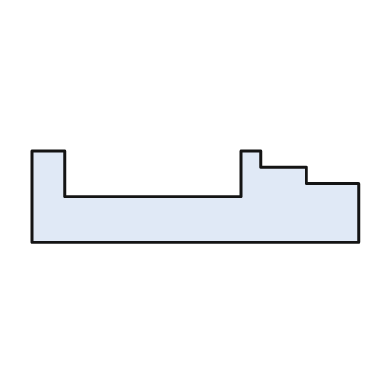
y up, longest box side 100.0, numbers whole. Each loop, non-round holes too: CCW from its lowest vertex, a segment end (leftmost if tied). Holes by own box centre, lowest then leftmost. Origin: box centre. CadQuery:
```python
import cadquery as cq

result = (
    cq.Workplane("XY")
    .moveTo(-50.0, -14.0)
    .lineTo(50.0, -14.0)
    .lineTo(50.0, 4.0)
    .lineTo(34.0, 4.0)
    .lineTo(34.0, 9.0)
    .lineTo(20.0, 9.0)
    .lineTo(20.0, 14.0)
    .lineTo(14.0, 14.0)
    .lineTo(14.0, 0.0)
    .lineTo(-40.0, 0.0)
    .lineTo(-40.0, 14.0)
    .lineTo(-50.0, 14.0)
    .close()
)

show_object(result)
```